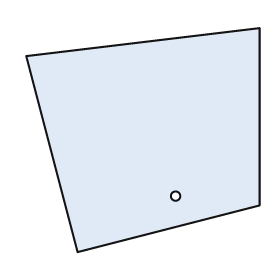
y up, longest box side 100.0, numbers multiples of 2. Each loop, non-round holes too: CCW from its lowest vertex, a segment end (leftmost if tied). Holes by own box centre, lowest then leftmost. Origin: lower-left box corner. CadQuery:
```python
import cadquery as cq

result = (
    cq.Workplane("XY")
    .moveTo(22.0, 0.0)
    .lineTo(100.0, 20.0)
    .lineTo(100.0, 96.0)
    .lineTo(0.0, 84.0)
    .close()
    .moveTo(64.0, 24.0)
    .circle(2.0)
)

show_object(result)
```